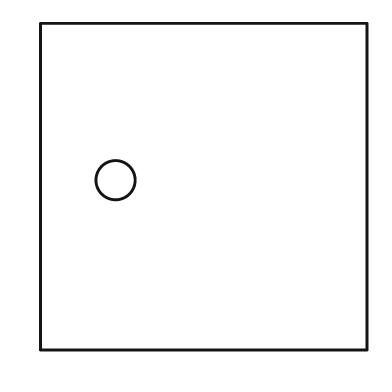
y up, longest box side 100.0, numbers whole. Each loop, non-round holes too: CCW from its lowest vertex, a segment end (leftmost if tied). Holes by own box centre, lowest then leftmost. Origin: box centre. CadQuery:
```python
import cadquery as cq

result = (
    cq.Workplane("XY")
    .moveTo(-50.0, -50.0)
    .lineTo(50.0, -50.0)
    .lineTo(50.0, 50.0)
    .lineTo(-50.0, 50.0)
    .close()
    .moveTo(-27.0, 2.0)
    .circle(6.0)
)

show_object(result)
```